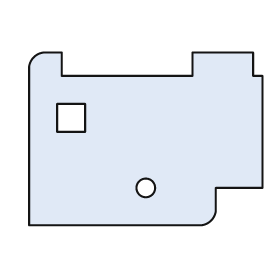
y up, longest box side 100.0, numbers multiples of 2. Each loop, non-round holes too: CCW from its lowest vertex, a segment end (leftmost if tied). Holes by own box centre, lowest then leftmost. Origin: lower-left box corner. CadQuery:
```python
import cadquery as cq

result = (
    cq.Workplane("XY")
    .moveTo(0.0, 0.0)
    .lineTo(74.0, 0.0)
    .threePointArc((78.0, 2.0), (80.0, 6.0))
    .lineTo(80.0, 16.0)
    .lineTo(100.0, 16.0)
    .lineTo(100.0, 64.0)
    .lineTo(96.0, 64.0)
    .lineTo(96.0, 74.0)
    .lineTo(70.0, 74.0)
    .lineTo(70.0, 64.0)
    .lineTo(14.0, 64.0)
    .lineTo(14.0, 74.0)
    .lineTo(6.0, 74.0)
    .threePointArc((2.0, 72.0), (0.0, 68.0))
    .close()
    .moveTo(50.0, 16.0)
    .circle(4.0)
    .moveTo(12.0, 40.0)
    .lineTo(24.0, 40.0)
    .lineTo(24.0, 52.0)
    .lineTo(12.0, 52.0)
    .close()
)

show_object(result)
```